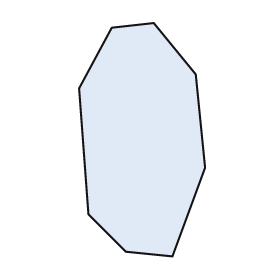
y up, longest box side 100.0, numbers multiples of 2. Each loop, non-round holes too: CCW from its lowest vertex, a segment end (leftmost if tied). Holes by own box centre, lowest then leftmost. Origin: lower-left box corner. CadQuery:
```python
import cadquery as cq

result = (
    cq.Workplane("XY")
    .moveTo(40.0, 0.0)
    .lineTo(54.0, 38.0)
    .lineTo(50.0, 78.0)
    .lineTo(32.0, 100.0)
    .lineTo(14.0, 98.0)
    .lineTo(0.0, 72.0)
    .lineTo(4.0, 18.0)
    .lineTo(20.0, 2.0)
    .close()
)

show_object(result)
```